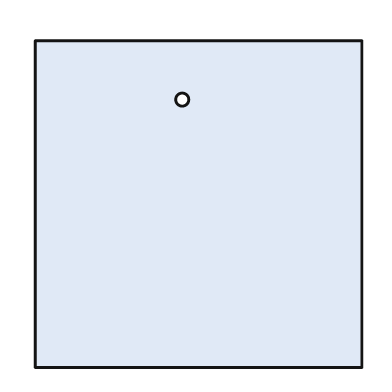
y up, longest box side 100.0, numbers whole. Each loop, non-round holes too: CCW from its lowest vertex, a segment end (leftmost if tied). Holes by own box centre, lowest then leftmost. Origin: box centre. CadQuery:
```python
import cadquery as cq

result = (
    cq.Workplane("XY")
    .moveTo(-50.0, -50.0)
    .lineTo(50.0, -50.0)
    .lineTo(50.0, 50.0)
    .lineTo(-50.0, 50.0)
    .close()
    .moveTo(-5.0, 32.0)
    .circle(2.0)
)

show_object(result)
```